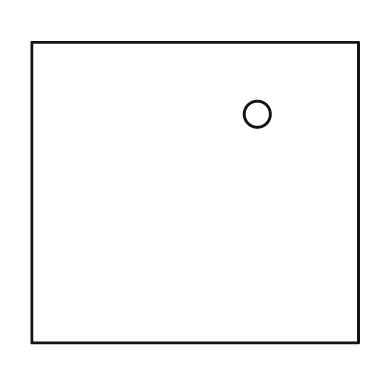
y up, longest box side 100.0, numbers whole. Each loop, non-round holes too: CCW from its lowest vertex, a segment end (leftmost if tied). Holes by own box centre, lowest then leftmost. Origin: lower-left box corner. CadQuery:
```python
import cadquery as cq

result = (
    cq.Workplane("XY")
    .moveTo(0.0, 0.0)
    .lineTo(100.0, 0.0)
    .lineTo(100.0, 92.0)
    .lineTo(0.0, 92.0)
    .close()
    .moveTo(69.0, 70.0)
    .circle(4.0)
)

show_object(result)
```